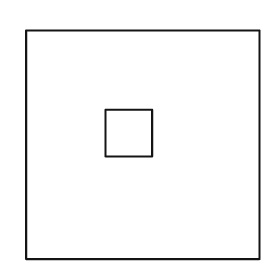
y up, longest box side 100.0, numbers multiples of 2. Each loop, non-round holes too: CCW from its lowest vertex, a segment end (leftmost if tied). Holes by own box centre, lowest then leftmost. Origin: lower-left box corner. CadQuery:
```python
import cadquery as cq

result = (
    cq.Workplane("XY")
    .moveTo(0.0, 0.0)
    .lineTo(100.0, 0.0)
    .lineTo(100.0, 98.0)
    .lineTo(0.0, 98.0)
    .close()
    .moveTo(34.0, 44.0)
    .lineTo(54.0, 44.0)
    .lineTo(54.0, 64.0)
    .lineTo(34.0, 64.0)
    .close()
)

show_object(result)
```